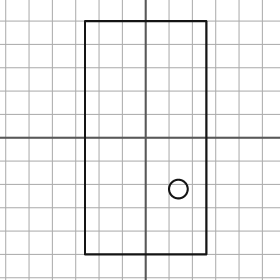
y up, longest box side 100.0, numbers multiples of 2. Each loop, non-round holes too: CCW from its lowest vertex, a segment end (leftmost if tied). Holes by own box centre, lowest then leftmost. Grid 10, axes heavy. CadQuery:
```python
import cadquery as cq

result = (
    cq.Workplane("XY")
    .moveTo(-26.0, -50.0)
    .lineTo(26.0, -50.0)
    .lineTo(26.0, 50.0)
    .lineTo(-26.0, 50.0)
    .close()
    .moveTo(14.0, -22.0)
    .circle(4.0)
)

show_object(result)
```